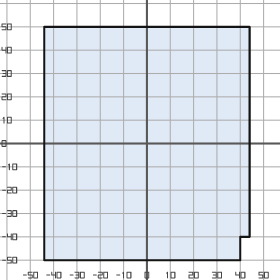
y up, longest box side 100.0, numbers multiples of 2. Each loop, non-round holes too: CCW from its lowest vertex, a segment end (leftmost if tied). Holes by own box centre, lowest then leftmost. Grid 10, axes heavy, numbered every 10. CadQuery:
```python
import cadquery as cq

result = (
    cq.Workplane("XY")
    .moveTo(-44.0, -50.0)
    .lineTo(40.0, -50.0)
    .lineTo(40.0, -40.0)
    .lineTo(44.0, -40.0)
    .lineTo(44.0, 50.0)
    .lineTo(-44.0, 50.0)
    .close()
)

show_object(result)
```